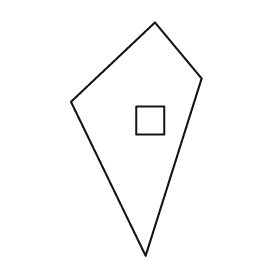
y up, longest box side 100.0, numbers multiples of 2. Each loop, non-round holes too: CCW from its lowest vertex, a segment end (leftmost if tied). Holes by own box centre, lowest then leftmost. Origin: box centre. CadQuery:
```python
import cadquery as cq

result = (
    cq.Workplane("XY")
    .moveTo(4.0, -50.0)
    .lineTo(28.0, 26.0)
    .lineTo(8.0, 50.0)
    .lineTo(-28.0, 16.0)
    .close()
    .moveTo(0.0, 2.0)
    .lineTo(12.0, 2.0)
    .lineTo(12.0, 14.0)
    .lineTo(0.0, 14.0)
    .close()
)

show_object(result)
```